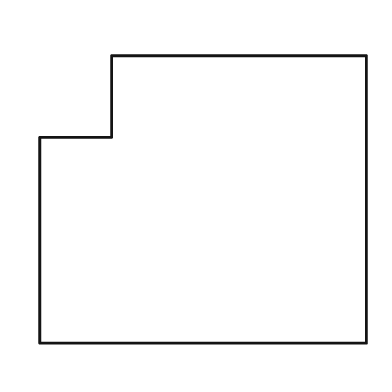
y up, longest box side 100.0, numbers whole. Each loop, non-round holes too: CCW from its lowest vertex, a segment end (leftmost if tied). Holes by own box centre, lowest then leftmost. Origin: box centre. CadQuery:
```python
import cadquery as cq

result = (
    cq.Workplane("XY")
    .moveTo(-50.0, -44.0)
    .lineTo(50.0, -44.0)
    .lineTo(50.0, 44.0)
    .lineTo(-28.0, 44.0)
    .lineTo(-28.0, 19.0)
    .lineTo(-50.0, 19.0)
    .close()
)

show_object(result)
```